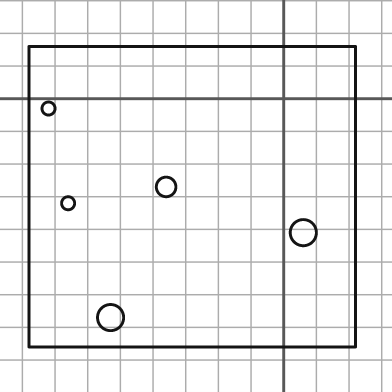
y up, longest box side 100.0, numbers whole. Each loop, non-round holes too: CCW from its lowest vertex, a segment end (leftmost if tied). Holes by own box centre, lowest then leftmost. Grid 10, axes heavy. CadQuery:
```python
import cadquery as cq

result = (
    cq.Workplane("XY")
    .moveTo(-78.0, -76.0)
    .lineTo(22.0, -76.0)
    .lineTo(22.0, 16.0)
    .lineTo(-78.0, 16.0)
    .close()
    .moveTo(-53.0, -67.0)
    .circle(4.0)
    .moveTo(6.0, -41.0)
    .circle(4.0)
    .moveTo(-66.0, -32.0)
    .circle(2.0)
    .moveTo(-36.0, -27.0)
    .circle(3.0)
    .moveTo(-72.0, -3.0)
    .circle(2.0)
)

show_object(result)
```